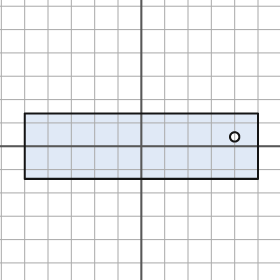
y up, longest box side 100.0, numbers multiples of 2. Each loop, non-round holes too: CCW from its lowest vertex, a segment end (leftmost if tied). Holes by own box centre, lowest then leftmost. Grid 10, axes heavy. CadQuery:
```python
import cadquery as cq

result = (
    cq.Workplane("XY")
    .moveTo(-50.0, -14.0)
    .lineTo(50.0, -14.0)
    .lineTo(50.0, 14.0)
    .lineTo(-50.0, 14.0)
    .close()
    .moveTo(40.0, 4.0)
    .circle(2.0)
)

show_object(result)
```